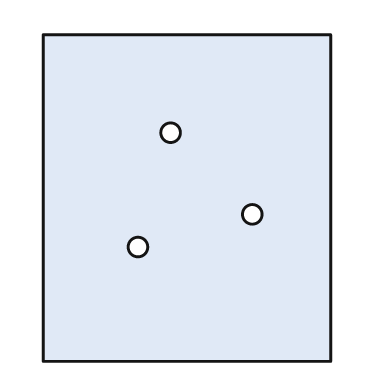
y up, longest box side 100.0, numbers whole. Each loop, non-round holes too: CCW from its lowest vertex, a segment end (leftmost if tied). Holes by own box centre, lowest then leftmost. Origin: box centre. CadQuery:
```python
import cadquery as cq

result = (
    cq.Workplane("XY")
    .moveTo(-44.0, -50.0)
    .lineTo(44.0, -50.0)
    .lineTo(44.0, 50.0)
    .lineTo(-44.0, 50.0)
    .close()
    .moveTo(-15.0, -15.0)
    .circle(3.0)
    .moveTo(20.0, -5.0)
    .circle(3.0)
    .moveTo(-5.0, 20.0)
    .circle(3.0)
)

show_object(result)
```